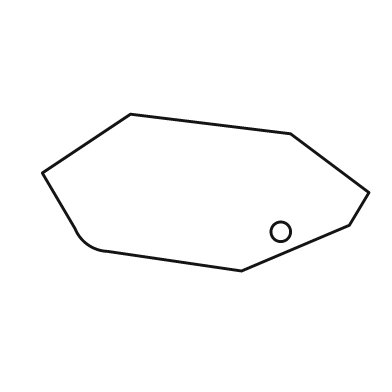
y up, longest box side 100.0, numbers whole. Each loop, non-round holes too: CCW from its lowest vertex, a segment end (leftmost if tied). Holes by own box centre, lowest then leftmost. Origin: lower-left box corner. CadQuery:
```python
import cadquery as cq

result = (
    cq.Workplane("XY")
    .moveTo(61.0, 0.0)
    .lineTo(94.0, 14.0)
    .lineTo(100.0, 24.0)
    .lineTo(76.0, 42.0)
    .lineTo(27.0, 48.0)
    .lineTo(0.0, 30.0)
    .lineTo(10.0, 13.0)
    .threePointArc((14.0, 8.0), (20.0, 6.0))
    .close()
    .moveTo(73.0, 12.0)
    .circle(3.0)
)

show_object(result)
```